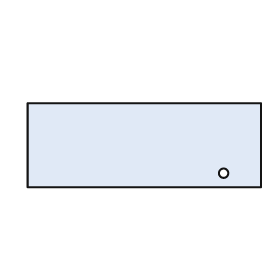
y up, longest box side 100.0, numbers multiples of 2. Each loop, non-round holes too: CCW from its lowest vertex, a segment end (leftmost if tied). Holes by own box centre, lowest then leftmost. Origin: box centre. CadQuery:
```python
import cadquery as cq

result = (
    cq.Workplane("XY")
    .moveTo(-50.0, -18.0)
    .lineTo(50.0, -18.0)
    .lineTo(50.0, 18.0)
    .lineTo(-50.0, 18.0)
    .close()
    .moveTo(34.0, -12.0)
    .circle(2.0)
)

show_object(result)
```